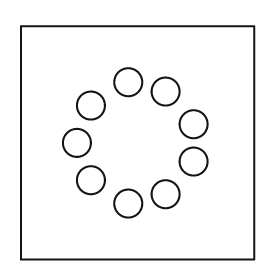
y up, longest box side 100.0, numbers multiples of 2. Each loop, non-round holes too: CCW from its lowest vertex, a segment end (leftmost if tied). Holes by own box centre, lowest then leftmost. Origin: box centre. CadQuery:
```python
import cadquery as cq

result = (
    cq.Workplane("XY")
    .moveTo(-50.0, -50.0)
    .lineTo(50.0, -50.0)
    .lineTo(50.0, 50.0)
    .lineTo(-50.0, 50.0)
    .close()
    .moveTo(-4.0, -26.0)
    .circle(6.0)
    .moveTo(12.0, -22.0)
    .circle(6.0)
    .moveTo(-20.0, -16.0)
    .circle(6.0)
    .moveTo(24.0, -8.0)
    .circle(6.0)
    .moveTo(-26.0, 0.0)
    .circle(6.0)
    .moveTo(24.0, 8.0)
    .circle(6.0)
    .moveTo(-20.0, 16.0)
    .circle(6.0)
    .moveTo(12.0, 22.0)
    .circle(6.0)
    .moveTo(-4.0, 26.0)
    .circle(6.0)
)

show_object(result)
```